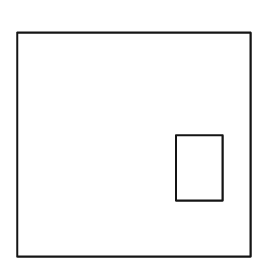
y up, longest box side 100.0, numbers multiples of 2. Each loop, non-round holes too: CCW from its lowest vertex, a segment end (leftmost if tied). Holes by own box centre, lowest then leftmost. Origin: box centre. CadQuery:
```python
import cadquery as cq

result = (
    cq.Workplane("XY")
    .moveTo(-50.0, -48.0)
    .lineTo(50.0, -48.0)
    .lineTo(50.0, 48.0)
    .lineTo(-50.0, 48.0)
    .close()
    .moveTo(18.0, -24.0)
    .lineTo(38.0, -24.0)
    .lineTo(38.0, 4.0)
    .lineTo(18.0, 4.0)
    .close()
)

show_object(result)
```